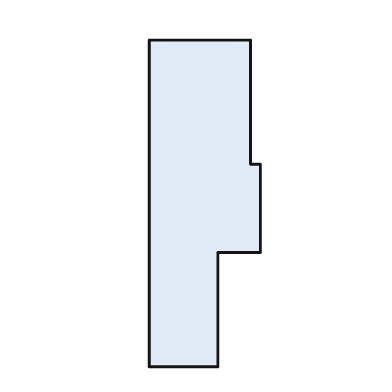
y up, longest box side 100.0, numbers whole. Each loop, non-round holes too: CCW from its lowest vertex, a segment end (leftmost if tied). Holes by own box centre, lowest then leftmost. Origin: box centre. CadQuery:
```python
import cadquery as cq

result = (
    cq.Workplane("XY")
    .moveTo(-17.0, -50.0)
    .lineTo(4.0, -50.0)
    .lineTo(4.0, -15.0)
    .lineTo(17.0, -15.0)
    .lineTo(17.0, 12.0)
    .lineTo(14.0, 12.0)
    .lineTo(14.0, 50.0)
    .lineTo(-17.0, 50.0)
    .close()
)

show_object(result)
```